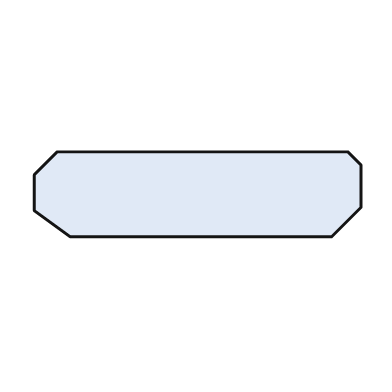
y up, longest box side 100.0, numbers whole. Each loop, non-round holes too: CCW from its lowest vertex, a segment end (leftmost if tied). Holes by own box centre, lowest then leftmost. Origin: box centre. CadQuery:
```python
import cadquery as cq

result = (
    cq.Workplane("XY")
    .moveTo(-39.0, -13.0)
    .lineTo(41.0, -13.0)
    .lineTo(50.0, -4.0)
    .lineTo(50.0, 9.0)
    .lineTo(46.0, 13.0)
    .lineTo(-43.0, 13.0)
    .lineTo(-50.0, 6.0)
    .lineTo(-50.0, -5.0)
    .close()
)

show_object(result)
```